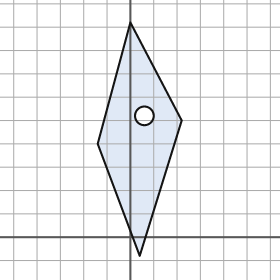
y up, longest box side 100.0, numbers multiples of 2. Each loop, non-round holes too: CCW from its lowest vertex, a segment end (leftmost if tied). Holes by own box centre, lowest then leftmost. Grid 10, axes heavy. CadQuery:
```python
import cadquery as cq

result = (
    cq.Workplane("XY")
    .moveTo(4.0, -8.0)
    .lineTo(22.0, 50.0)
    .lineTo(0.0, 92.0)
    .lineTo(-14.0, 40.0)
    .close()
    .moveTo(6.0, 52.0)
    .circle(4.0)
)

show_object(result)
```